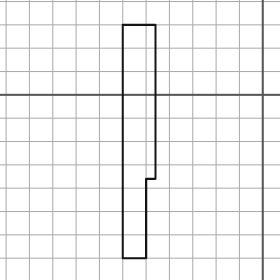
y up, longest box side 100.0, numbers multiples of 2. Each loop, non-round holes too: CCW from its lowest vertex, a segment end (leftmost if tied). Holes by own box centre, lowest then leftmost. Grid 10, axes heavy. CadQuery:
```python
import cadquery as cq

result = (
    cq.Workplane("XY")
    .moveTo(-60.0, -70.0)
    .lineTo(-50.0, -70.0)
    .lineTo(-50.0, -36.0)
    .lineTo(-46.0, -36.0)
    .lineTo(-46.0, 30.0)
    .lineTo(-60.0, 30.0)
    .close()
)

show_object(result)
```